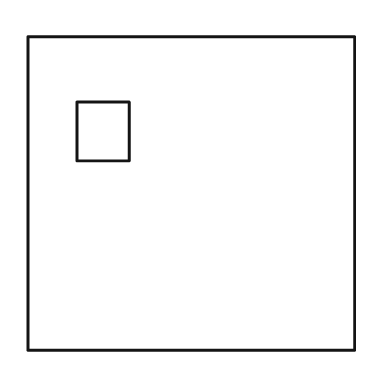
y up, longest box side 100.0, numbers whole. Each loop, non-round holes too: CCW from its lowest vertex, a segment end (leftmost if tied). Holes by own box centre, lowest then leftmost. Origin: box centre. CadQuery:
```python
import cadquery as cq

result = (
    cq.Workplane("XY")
    .moveTo(-50.0, -48.0)
    .lineTo(50.0, -48.0)
    .lineTo(50.0, 48.0)
    .lineTo(-50.0, 48.0)
    .close()
    .moveTo(-35.0, 10.0)
    .lineTo(-19.0, 10.0)
    .lineTo(-19.0, 28.0)
    .lineTo(-35.0, 28.0)
    .close()
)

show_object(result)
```